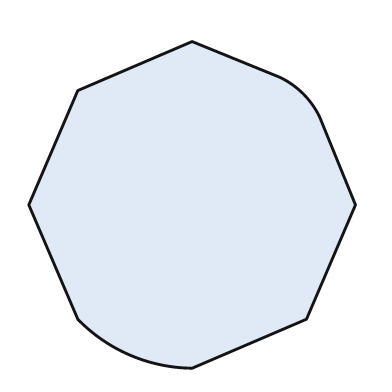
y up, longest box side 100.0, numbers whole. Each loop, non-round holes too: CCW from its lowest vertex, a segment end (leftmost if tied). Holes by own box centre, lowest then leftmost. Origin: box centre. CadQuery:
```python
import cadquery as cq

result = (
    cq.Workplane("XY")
    .moveTo(0.0, -50.0)
    .lineTo(35.0, -35.0)
    .lineTo(50.0, 0.0)
    .lineTo(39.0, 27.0)
    .threePointArc((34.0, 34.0), (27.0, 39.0))
    .lineTo(0.0, 50.0)
    .lineTo(-35.0, 35.0)
    .lineTo(-50.0, 0.0)
    .lineTo(-35.0, -35.0)
    .threePointArc((-19.0, -46.0), (0.0, -50.0))
    .close()
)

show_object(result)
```